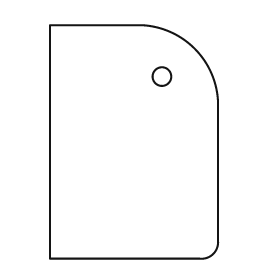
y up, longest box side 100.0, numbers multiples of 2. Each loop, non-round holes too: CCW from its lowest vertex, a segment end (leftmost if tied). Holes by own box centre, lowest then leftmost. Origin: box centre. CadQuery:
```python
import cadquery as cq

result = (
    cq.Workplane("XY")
    .moveTo(-36.0, -50.0)
    .lineTo(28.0, -50.0)
    .threePointArc((34.0, -48.0), (36.0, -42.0))
    .lineTo(36.0, 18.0)
    .threePointArc((26.0, 40.0), (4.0, 50.0))
    .lineTo(-36.0, 50.0)
    .close()
    .moveTo(12.0, 28.0)
    .circle(4.0)
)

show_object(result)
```